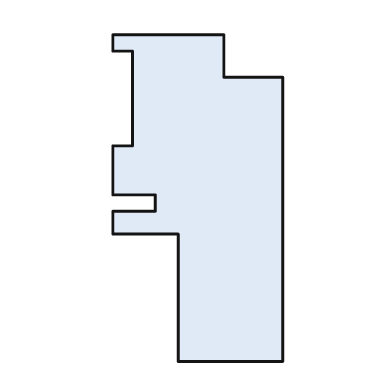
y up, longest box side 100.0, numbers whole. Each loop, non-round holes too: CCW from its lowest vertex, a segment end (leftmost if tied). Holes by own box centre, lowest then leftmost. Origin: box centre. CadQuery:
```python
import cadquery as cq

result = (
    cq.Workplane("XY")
    .moveTo(-6.0, -50.0)
    .lineTo(26.0, -50.0)
    .lineTo(26.0, 37.0)
    .lineTo(8.0, 37.0)
    .lineTo(8.0, 50.0)
    .lineTo(-26.0, 50.0)
    .lineTo(-26.0, 45.0)
    .lineTo(-20.0, 45.0)
    .lineTo(-20.0, 16.0)
    .lineTo(-26.0, 16.0)
    .lineTo(-26.0, 1.0)
    .lineTo(-13.0, 1.0)
    .lineTo(-13.0, -4.0)
    .lineTo(-26.0, -4.0)
    .lineTo(-26.0, -11.0)
    .lineTo(-6.0, -11.0)
    .close()
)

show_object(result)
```